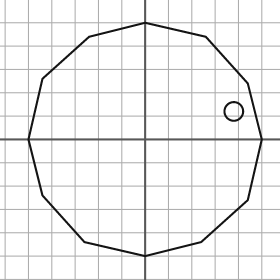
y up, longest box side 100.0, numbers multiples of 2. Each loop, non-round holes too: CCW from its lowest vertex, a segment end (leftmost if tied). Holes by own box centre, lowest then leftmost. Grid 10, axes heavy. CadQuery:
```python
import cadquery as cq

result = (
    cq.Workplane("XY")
    .moveTo(0.0, -50.0)
    .lineTo(24.0, -44.0)
    .lineTo(44.0, -26.0)
    .lineTo(50.0, 0.0)
    .lineTo(44.0, 24.0)
    .lineTo(26.0, 44.0)
    .lineTo(0.0, 50.0)
    .lineTo(-24.0, 44.0)
    .lineTo(-44.0, 26.0)
    .lineTo(-50.0, 0.0)
    .lineTo(-44.0, -24.0)
    .lineTo(-26.0, -44.0)
    .close()
    .moveTo(38.0, 12.0)
    .circle(4.0)
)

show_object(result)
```